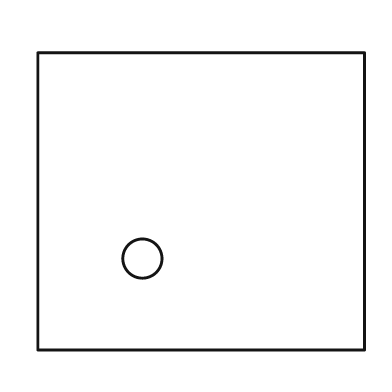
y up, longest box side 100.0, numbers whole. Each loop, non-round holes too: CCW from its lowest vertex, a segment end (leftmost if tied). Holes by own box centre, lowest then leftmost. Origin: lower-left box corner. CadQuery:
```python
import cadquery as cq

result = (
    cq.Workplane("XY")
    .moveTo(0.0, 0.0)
    .lineTo(100.0, 0.0)
    .lineTo(100.0, 91.0)
    .lineTo(0.0, 91.0)
    .close()
    .moveTo(32.0, 28.0)
    .circle(6.0)
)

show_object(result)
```